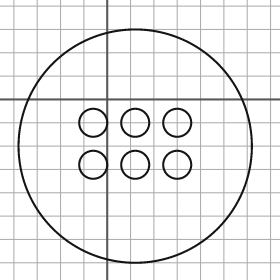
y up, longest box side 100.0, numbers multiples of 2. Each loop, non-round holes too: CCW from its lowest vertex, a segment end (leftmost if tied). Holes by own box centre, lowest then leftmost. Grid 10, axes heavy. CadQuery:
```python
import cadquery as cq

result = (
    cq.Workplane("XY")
    .moveTo(12.0, -20.0)
    .circle(50.0)
    .moveTo(-6.0, -28.0)
    .circle(6.0)
    .moveTo(12.0, -28.0)
    .circle(6.0)
    .moveTo(30.0, -28.0)
    .circle(6.0)
    .moveTo(-6.0, -10.0)
    .circle(6.0)
    .moveTo(12.0, -10.0)
    .circle(6.0)
    .moveTo(30.0, -10.0)
    .circle(6.0)
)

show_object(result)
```